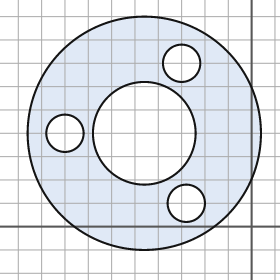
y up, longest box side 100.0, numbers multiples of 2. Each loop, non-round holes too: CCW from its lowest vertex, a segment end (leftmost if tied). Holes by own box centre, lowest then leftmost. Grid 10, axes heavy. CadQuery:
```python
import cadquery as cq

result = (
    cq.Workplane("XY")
    .moveTo(-46.0, 40.0)
    .circle(50.0)
    .moveTo(-28.0, 10.0)
    .circle(8.0)
    .moveTo(-80.0, 40.0)
    .circle(8.0)
    .moveTo(-46.0, 40.0)
    .circle(22.0)
    .moveTo(-30.0, 70.0)
    .circle(8.0)
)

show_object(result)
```